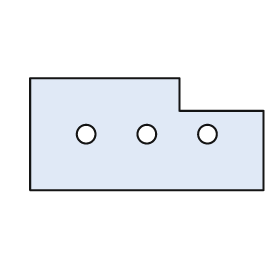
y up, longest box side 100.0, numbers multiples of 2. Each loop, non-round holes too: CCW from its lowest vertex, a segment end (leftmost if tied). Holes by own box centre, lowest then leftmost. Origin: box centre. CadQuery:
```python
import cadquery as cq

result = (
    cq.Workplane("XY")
    .moveTo(-50.0, -24.0)
    .lineTo(50.0, -24.0)
    .lineTo(50.0, 10.0)
    .lineTo(14.0, 10.0)
    .lineTo(14.0, 24.0)
    .lineTo(-50.0, 24.0)
    .close()
    .moveTo(-26.0, 0.0)
    .circle(4.0)
    .moveTo(0.0, 0.0)
    .circle(4.0)
    .moveTo(26.0, 0.0)
    .circle(4.0)
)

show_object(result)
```